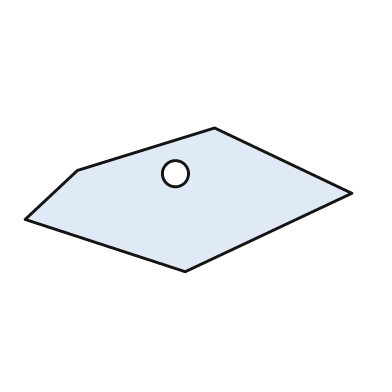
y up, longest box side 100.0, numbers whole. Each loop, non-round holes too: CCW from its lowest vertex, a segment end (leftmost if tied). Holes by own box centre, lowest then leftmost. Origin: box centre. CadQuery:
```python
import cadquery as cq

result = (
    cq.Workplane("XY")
    .moveTo(-1.0, -22.0)
    .lineTo(50.0, 2.0)
    .lineTo(8.0, 22.0)
    .lineTo(-34.0, 9.0)
    .lineTo(-50.0, -6.0)
    .close()
    .moveTo(-4.0, 8.0)
    .circle(4.0)
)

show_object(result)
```